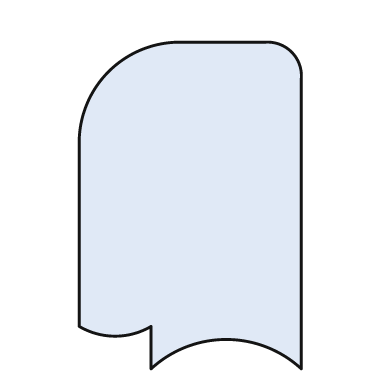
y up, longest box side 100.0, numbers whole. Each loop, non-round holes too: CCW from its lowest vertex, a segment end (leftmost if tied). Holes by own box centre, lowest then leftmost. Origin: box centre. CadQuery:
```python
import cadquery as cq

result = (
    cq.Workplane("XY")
    .moveTo(-12.0, -50.0)
    .threePointArc((11.0, -41.0), (34.0, -50.0))
    .lineTo(34.0, 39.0)
    .threePointArc((31.0, 47.0), (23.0, 50.0))
    .lineTo(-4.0, 50.0)
    .threePointArc((-25.0, 41.0), (-34.0, 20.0))
    .lineTo(-34.0, -37.0)
    .threePointArc((-23.0, -40.0), (-12.0, -37.0))
    .close()
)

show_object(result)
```